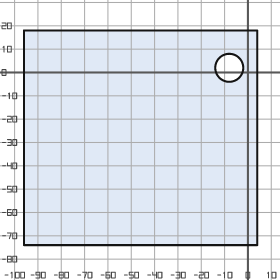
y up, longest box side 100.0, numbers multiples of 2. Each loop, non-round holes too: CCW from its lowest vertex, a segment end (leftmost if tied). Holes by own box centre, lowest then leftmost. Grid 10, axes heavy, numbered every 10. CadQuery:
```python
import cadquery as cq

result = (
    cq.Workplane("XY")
    .moveTo(-96.0, -74.0)
    .lineTo(4.0, -74.0)
    .lineTo(4.0, 18.0)
    .lineTo(-96.0, 18.0)
    .close()
    .moveTo(-8.0, 2.0)
    .circle(6.0)
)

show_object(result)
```